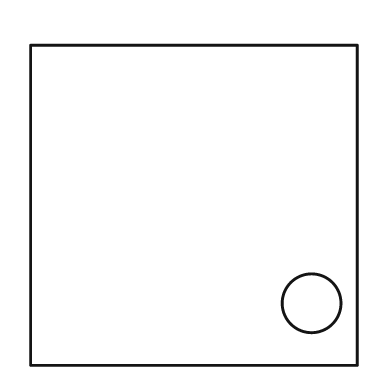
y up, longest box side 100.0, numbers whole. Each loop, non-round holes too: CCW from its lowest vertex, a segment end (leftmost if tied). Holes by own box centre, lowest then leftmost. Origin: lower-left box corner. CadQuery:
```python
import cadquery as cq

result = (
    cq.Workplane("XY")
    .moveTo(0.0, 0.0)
    .lineTo(100.0, 0.0)
    .lineTo(100.0, 98.0)
    .lineTo(0.0, 98.0)
    .close()
    .moveTo(86.0, 19.0)
    .circle(9.0)
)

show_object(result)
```